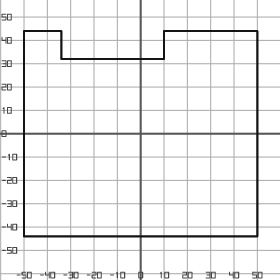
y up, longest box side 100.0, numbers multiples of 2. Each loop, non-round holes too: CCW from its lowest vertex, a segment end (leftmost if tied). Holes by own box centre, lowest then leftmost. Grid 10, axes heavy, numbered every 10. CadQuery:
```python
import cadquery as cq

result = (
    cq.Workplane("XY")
    .moveTo(-50.0, -44.0)
    .lineTo(50.0, -44.0)
    .lineTo(50.0, 44.0)
    .lineTo(10.0, 44.0)
    .lineTo(10.0, 32.0)
    .lineTo(-34.0, 32.0)
    .lineTo(-34.0, 44.0)
    .lineTo(-50.0, 44.0)
    .close()
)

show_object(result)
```